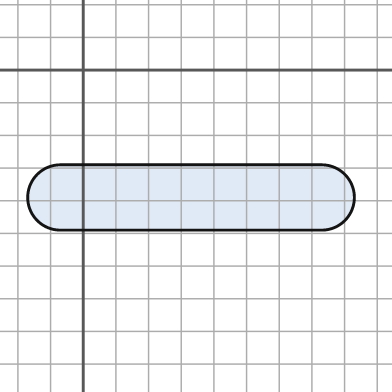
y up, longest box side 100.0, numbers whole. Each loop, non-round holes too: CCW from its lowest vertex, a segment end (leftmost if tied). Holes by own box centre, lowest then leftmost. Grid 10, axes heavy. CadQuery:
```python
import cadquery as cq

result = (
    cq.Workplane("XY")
    .moveTo(-7.0, -49.0)
    .lineTo(73.0, -49.0)
    .threePointArc((83.0, -39.0), (73.0, -29.0))
    .lineTo(-7.0, -29.0)
    .threePointArc((-17.0, -39.0), (-7.0, -49.0))
    .close()
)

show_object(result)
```